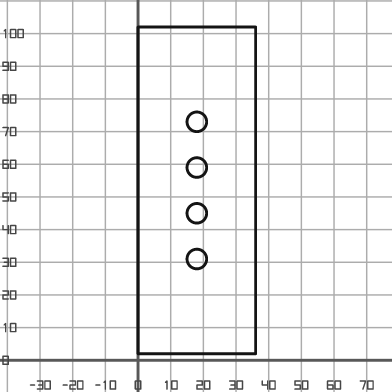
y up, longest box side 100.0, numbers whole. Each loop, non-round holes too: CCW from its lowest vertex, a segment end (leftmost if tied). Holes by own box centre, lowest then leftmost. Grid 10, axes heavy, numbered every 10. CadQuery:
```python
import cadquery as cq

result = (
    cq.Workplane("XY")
    .moveTo(0.0, 2.0)
    .lineTo(36.0, 2.0)
    .lineTo(36.0, 102.0)
    .lineTo(0.0, 102.0)
    .close()
    .moveTo(18.0, 31.0)
    .circle(3.0)
    .moveTo(18.0, 45.0)
    .circle(3.0)
    .moveTo(18.0, 59.0)
    .circle(3.0)
    .moveTo(18.0, 73.0)
    .circle(3.0)
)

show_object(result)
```